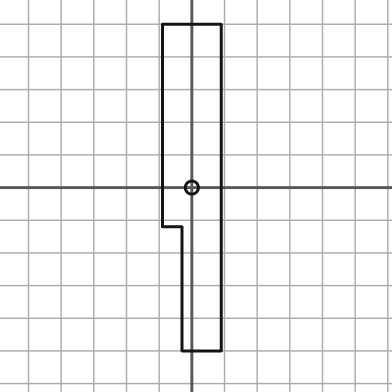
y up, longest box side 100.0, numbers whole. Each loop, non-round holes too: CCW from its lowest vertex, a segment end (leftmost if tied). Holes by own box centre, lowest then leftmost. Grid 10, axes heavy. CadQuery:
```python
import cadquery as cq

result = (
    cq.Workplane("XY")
    .moveTo(-3.0, -50.0)
    .lineTo(9.0, -50.0)
    .lineTo(9.0, 50.0)
    .lineTo(-9.0, 50.0)
    .lineTo(-9.0, -12.0)
    .lineTo(-3.0, -12.0)
    .close()
    .moveTo(0.0, 0.0)
    .circle(2.0)
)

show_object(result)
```